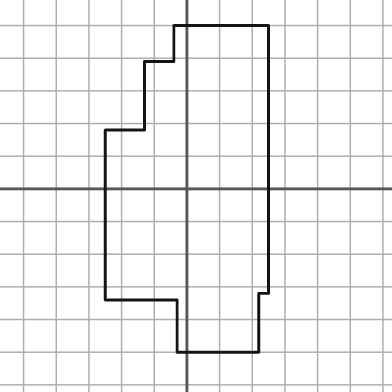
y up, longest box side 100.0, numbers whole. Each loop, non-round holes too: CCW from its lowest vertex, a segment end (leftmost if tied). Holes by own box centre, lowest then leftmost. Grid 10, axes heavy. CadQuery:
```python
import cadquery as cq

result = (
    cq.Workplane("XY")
    .moveTo(-3.0, -50.0)
    .lineTo(22.0, -50.0)
    .lineTo(22.0, -32.0)
    .lineTo(25.0, -32.0)
    .lineTo(25.0, 50.0)
    .lineTo(-4.0, 50.0)
    .lineTo(-4.0, 39.0)
    .lineTo(-13.0, 39.0)
    .lineTo(-13.0, 18.0)
    .lineTo(-25.0, 18.0)
    .lineTo(-25.0, -34.0)
    .lineTo(-3.0, -34.0)
    .close()
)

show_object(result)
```